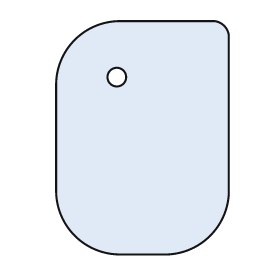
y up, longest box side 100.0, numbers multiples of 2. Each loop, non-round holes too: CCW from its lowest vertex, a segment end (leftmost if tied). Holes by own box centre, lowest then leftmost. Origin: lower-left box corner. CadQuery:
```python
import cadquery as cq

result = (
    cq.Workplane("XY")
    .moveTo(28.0, 0.0)
    .lineTo(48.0, 0.0)
    .threePointArc((66.0, 8.0), (74.0, 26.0))
    .lineTo(74.0, 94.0)
    .threePointArc((72.0, 98.0), (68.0, 100.0))
    .lineTo(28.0, 100.0)
    .threePointArc((8.0, 92.0), (0.0, 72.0))
    .lineTo(0.0, 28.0)
    .threePointArc((8.0, 8.0), (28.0, 0.0))
    .close()
    .moveTo(26.0, 76.0)
    .circle(4.0)
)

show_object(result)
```